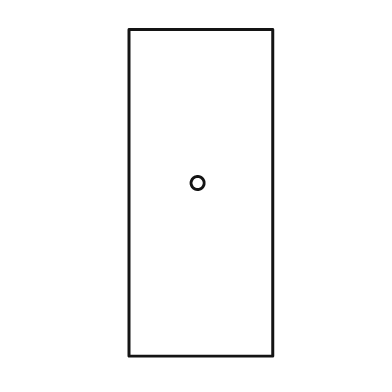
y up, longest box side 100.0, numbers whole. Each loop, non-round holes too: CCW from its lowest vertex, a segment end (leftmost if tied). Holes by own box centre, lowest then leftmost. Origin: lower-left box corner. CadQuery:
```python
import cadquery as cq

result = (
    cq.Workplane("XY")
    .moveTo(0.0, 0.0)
    .lineTo(44.0, 0.0)
    .lineTo(44.0, 100.0)
    .lineTo(0.0, 100.0)
    .close()
    .moveTo(21.0, 53.0)
    .circle(2.0)
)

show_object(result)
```